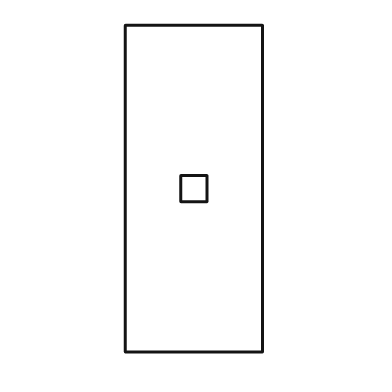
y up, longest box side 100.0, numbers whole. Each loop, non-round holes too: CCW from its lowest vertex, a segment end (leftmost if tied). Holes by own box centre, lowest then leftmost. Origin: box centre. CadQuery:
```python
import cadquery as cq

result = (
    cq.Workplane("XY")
    .moveTo(-21.0, -50.0)
    .lineTo(21.0, -50.0)
    .lineTo(21.0, 50.0)
    .lineTo(-21.0, 50.0)
    .close()
    .moveTo(-4.0, -4.0)
    .lineTo(4.0, -4.0)
    .lineTo(4.0, 4.0)
    .lineTo(-4.0, 4.0)
    .close()
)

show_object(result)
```